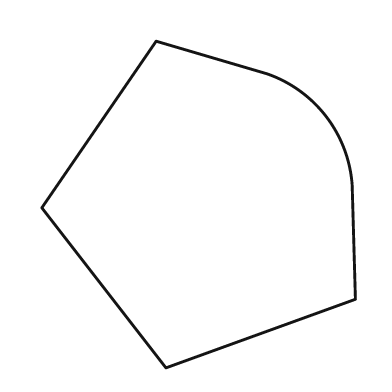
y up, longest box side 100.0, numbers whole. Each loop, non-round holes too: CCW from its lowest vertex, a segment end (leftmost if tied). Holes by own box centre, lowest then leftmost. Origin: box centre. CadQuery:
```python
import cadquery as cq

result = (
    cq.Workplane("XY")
    .moveTo(-10.0, -50.0)
    .lineTo(48.0, -29.0)
    .lineTo(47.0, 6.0)
    .threePointArc((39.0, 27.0), (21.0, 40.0))
    .lineTo(-13.0, 50.0)
    .lineTo(-48.0, -1.0)
    .close()
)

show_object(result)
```